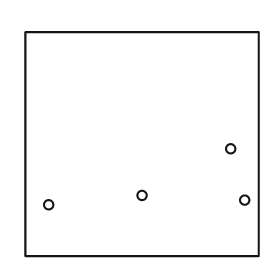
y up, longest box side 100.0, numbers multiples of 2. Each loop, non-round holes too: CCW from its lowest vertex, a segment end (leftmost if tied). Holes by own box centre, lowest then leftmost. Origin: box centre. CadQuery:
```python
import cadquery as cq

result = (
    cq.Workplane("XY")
    .moveTo(-50.0, -48.0)
    .lineTo(50.0, -48.0)
    .lineTo(50.0, 48.0)
    .lineTo(-50.0, 48.0)
    .close()
    .moveTo(-40.0, -26.0)
    .circle(2.0)
    .moveTo(44.0, -24.0)
    .circle(2.0)
    .moveTo(0.0, -22.0)
    .circle(2.0)
    .moveTo(38.0, -2.0)
    .circle(2.0)
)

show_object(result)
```